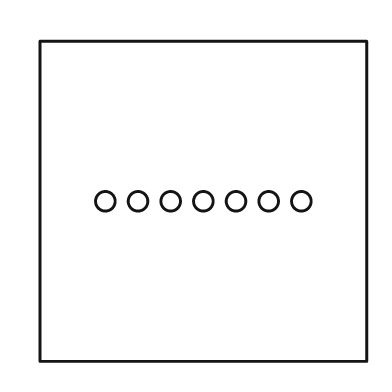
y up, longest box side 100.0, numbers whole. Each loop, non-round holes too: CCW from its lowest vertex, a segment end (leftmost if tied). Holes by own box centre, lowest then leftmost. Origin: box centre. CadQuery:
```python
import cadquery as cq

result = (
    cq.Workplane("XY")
    .moveTo(-50.0, -49.0)
    .lineTo(50.0, -49.0)
    .lineTo(50.0, 49.0)
    .lineTo(-50.0, 49.0)
    .close()
    .moveTo(-30.0, 0.0)
    .circle(3.0)
    .moveTo(-20.0, 0.0)
    .circle(3.0)
    .moveTo(-10.0, 0.0)
    .circle(3.0)
    .moveTo(0.0, 0.0)
    .circle(3.0)
    .moveTo(10.0, 0.0)
    .circle(3.0)
    .moveTo(20.0, 0.0)
    .circle(3.0)
    .moveTo(30.0, 0.0)
    .circle(3.0)
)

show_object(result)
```